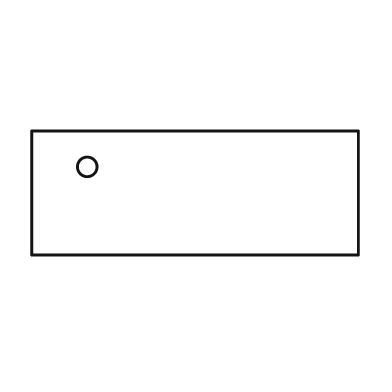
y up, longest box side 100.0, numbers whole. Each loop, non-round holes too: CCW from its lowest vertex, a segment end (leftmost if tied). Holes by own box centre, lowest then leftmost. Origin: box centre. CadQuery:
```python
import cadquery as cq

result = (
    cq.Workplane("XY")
    .moveTo(-50.0, -19.0)
    .lineTo(50.0, -19.0)
    .lineTo(50.0, 19.0)
    .lineTo(-50.0, 19.0)
    .close()
    .moveTo(-33.0, 8.0)
    .circle(3.0)
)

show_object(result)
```